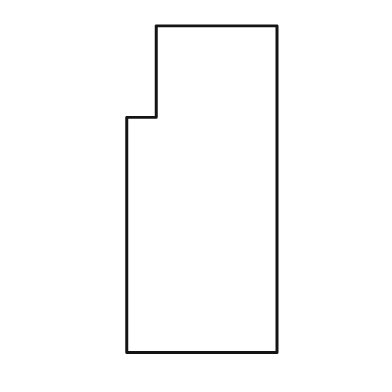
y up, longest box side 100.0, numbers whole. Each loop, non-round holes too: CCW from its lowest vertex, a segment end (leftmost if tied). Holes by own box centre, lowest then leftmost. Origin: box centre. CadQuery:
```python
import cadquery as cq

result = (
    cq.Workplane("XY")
    .moveTo(-23.0, -50.0)
    .lineTo(23.0, -50.0)
    .lineTo(23.0, 50.0)
    .lineTo(-14.0, 50.0)
    .lineTo(-14.0, 22.0)
    .lineTo(-23.0, 22.0)
    .close()
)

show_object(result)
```